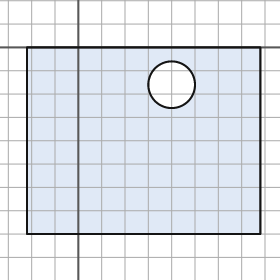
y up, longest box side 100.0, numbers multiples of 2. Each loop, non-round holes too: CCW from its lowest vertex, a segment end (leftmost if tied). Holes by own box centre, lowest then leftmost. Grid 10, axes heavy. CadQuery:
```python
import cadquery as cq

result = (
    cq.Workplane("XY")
    .moveTo(-22.0, -80.0)
    .lineTo(78.0, -80.0)
    .lineTo(78.0, 0.0)
    .lineTo(-22.0, 0.0)
    .close()
    .moveTo(40.0, -16.0)
    .circle(10.0)
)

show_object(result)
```